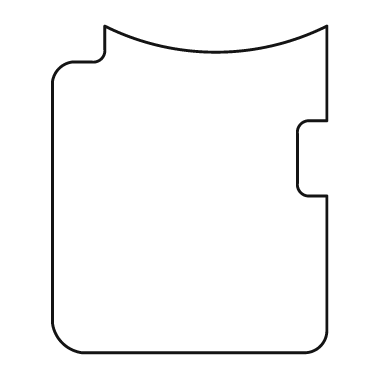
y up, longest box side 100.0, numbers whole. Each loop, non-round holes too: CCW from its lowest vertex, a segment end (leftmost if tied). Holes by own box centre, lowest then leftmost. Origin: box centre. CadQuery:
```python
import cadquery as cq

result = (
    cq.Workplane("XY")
    .moveTo(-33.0, -50.0)
    .lineTo(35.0, -50.0)
    .threePointArc((40.0, -48.0), (42.0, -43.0))
    .lineTo(42.0, -2.0)
    .lineTo(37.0, -2.0)
    .threePointArc((34.0, -1.0), (33.0, 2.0))
    .lineTo(33.0, 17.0)
    .threePointArc((34.0, 20.0), (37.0, 21.0))
    .lineTo(42.0, 21.0)
    .lineTo(42.0, 50.0)
    .threePointArc((8.0, 42.0), (-26.0, 50.0))
    .lineTo(-26.0, 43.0)
    .threePointArc((-27.0, 40.0), (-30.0, 39.0))
    .lineTo(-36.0, 39.0)
    .threePointArc((-40.0, 37.0), (-42.0, 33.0))
    .lineTo(-42.0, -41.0)
    .threePointArc((-39.0, -47.0), (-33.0, -50.0))
    .close()
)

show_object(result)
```